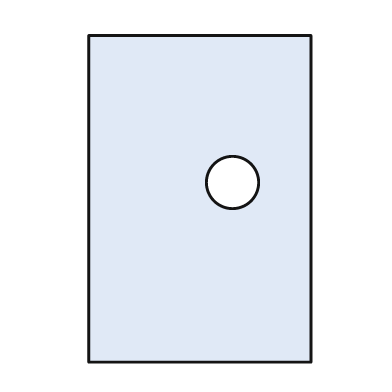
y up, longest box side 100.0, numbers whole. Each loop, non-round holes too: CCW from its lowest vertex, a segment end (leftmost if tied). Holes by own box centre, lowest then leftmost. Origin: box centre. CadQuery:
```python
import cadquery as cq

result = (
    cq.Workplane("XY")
    .moveTo(-34.0, -50.0)
    .lineTo(34.0, -50.0)
    .lineTo(34.0, 50.0)
    .lineTo(-34.0, 50.0)
    .close()
    .moveTo(10.0, 5.0)
    .circle(8.0)
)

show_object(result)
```